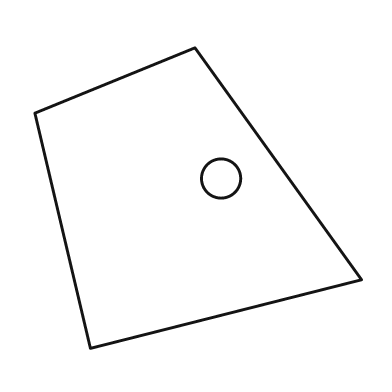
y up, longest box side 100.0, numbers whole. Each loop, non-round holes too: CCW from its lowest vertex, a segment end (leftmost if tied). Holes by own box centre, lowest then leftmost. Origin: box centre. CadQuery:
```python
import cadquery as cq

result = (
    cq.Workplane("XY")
    .moveTo(-33.0, -46.0)
    .lineTo(50.0, -25.0)
    .lineTo(-1.0, 46.0)
    .lineTo(-50.0, 26.0)
    .close()
    .moveTo(7.0, 6.0)
    .circle(6.0)
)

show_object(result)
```